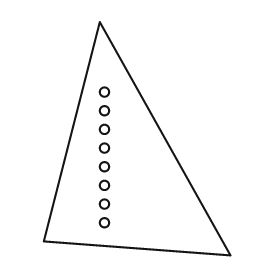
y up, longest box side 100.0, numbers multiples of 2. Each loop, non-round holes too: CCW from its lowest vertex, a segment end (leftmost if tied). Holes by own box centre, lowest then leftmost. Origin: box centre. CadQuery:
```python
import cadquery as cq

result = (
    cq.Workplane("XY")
    .moveTo(40.0, -50.0)
    .lineTo(-16.0, 50.0)
    .lineTo(-40.0, -44.0)
    .close()
    .moveTo(-14.0, -36.0)
    .circle(2.0)
    .moveTo(-14.0, -28.0)
    .circle(2.0)
    .moveTo(-14.0, -20.0)
    .circle(2.0)
    .moveTo(-14.0, -12.0)
    .circle(2.0)
    .moveTo(-14.0, -4.0)
    .circle(2.0)
    .moveTo(-14.0, 4.0)
    .circle(2.0)
    .moveTo(-14.0, 12.0)
    .circle(2.0)
    .moveTo(-14.0, 20.0)
    .circle(2.0)
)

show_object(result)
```